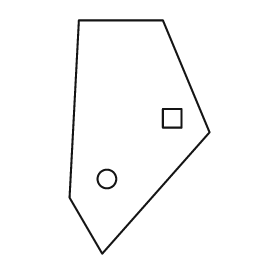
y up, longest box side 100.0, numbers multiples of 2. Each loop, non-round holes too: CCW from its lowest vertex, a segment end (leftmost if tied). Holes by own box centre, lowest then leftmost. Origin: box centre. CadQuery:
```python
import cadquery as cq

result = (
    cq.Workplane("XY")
    .moveTo(-16.0, -50.0)
    .lineTo(30.0, 2.0)
    .lineTo(10.0, 50.0)
    .lineTo(-26.0, 50.0)
    .lineTo(-30.0, -26.0)
    .close()
    .moveTo(-14.0, -18.0)
    .circle(4.0)
    .moveTo(10.0, 4.0)
    .lineTo(18.0, 4.0)
    .lineTo(18.0, 12.0)
    .lineTo(10.0, 12.0)
    .close()
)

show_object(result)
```